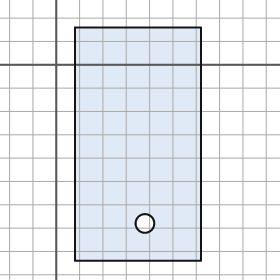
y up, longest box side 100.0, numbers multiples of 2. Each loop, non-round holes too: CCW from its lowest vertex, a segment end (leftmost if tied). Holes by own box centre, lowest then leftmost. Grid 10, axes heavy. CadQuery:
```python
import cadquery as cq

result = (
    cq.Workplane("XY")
    .moveTo(8.0, -84.0)
    .lineTo(62.0, -84.0)
    .lineTo(62.0, 16.0)
    .lineTo(8.0, 16.0)
    .close()
    .moveTo(38.0, -68.0)
    .circle(4.0)
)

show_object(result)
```